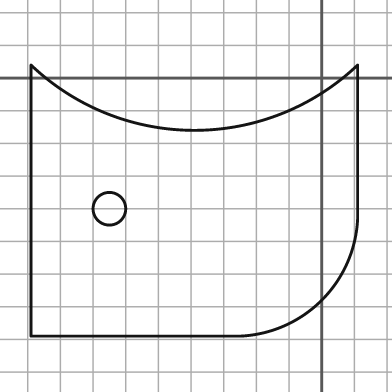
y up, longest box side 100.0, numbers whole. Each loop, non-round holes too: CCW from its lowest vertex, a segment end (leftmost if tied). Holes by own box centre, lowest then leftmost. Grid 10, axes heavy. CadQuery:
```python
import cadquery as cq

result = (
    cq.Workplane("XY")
    .moveTo(-89.0, -79.0)
    .lineTo(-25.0, -79.0)
    .threePointArc((0.0, -68.0), (11.0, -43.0))
    .lineTo(11.0, 4.0)
    .threePointArc((-39.0, -16.0), (-89.0, 4.0))
    .close()
    .moveTo(-65.0, -40.0)
    .circle(5.0)
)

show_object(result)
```